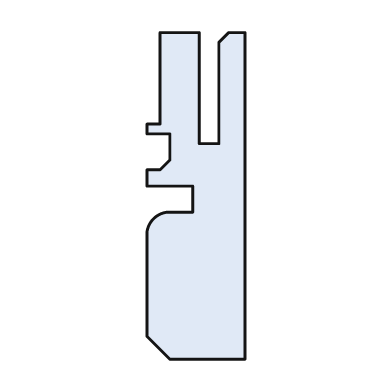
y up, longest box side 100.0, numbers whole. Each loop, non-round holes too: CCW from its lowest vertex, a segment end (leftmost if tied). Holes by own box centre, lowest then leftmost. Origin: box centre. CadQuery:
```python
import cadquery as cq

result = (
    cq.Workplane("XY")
    .moveTo(-8.0, -50.0)
    .lineTo(15.0, -50.0)
    .lineTo(15.0, 50.0)
    .lineTo(10.0, 50.0)
    .lineTo(7.0, 47.0)
    .lineTo(7.0, 16.0)
    .lineTo(1.0, 16.0)
    .lineTo(1.0, 50.0)
    .lineTo(-11.0, 50.0)
    .lineTo(-11.0, 22.0)
    .lineTo(-15.0, 22.0)
    .lineTo(-15.0, 19.0)
    .lineTo(-8.0, 19.0)
    .lineTo(-8.0, 11.0)
    .lineTo(-11.0, 8.0)
    .lineTo(-15.0, 8.0)
    .lineTo(-15.0, 3.0)
    .lineTo(-1.0, 3.0)
    .lineTo(-1.0, -5.0)
    .lineTo(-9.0, -5.0)
    .threePointArc((-13.0, -7.0), (-15.0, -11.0))
    .lineTo(-15.0, -43.0)
    .close()
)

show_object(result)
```